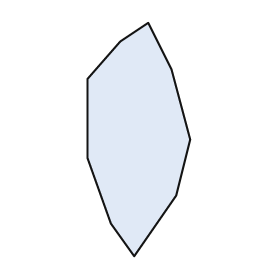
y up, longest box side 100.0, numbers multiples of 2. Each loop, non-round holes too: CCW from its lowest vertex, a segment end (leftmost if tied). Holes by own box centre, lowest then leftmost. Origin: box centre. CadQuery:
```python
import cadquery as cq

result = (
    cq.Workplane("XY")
    .moveTo(-2.0, -50.0)
    .lineTo(16.0, -24.0)
    .lineTo(22.0, 0.0)
    .lineTo(14.0, 30.0)
    .lineTo(4.0, 50.0)
    .lineTo(-8.0, 42.0)
    .lineTo(-22.0, 26.0)
    .lineTo(-22.0, -8.0)
    .lineTo(-12.0, -36.0)
    .close()
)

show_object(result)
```